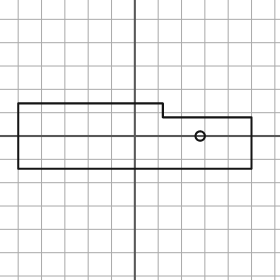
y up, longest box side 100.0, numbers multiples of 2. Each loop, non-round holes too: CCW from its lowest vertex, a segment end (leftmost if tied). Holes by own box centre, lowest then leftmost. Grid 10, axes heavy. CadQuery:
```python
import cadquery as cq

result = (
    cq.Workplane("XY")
    .moveTo(-50.0, -14.0)
    .lineTo(50.0, -14.0)
    .lineTo(50.0, 8.0)
    .lineTo(12.0, 8.0)
    .lineTo(12.0, 14.0)
    .lineTo(-50.0, 14.0)
    .close()
    .moveTo(28.0, 0.0)
    .circle(2.0)
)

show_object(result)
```